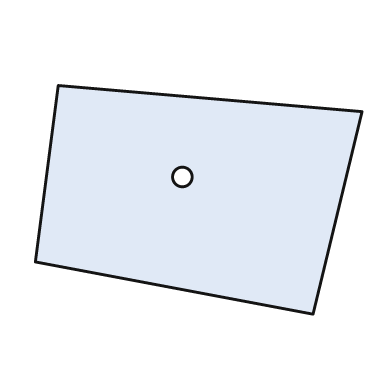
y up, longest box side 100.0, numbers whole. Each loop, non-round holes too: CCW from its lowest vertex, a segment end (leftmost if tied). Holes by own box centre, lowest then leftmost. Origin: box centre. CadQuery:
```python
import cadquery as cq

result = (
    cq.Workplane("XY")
    .moveTo(35.0, -35.0)
    .lineTo(50.0, 27.0)
    .lineTo(-43.0, 35.0)
    .lineTo(-50.0, -19.0)
    .close()
    .moveTo(-5.0, 7.0)
    .circle(3.0)
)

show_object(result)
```